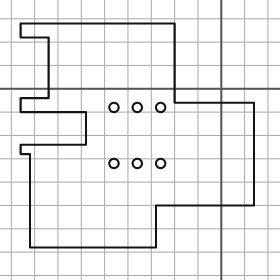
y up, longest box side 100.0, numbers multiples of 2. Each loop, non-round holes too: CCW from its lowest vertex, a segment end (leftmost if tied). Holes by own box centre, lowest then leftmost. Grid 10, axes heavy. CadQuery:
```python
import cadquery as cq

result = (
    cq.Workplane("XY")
    .moveTo(-82.0, -68.0)
    .lineTo(-28.0, -68.0)
    .lineTo(-28.0, -50.0)
    .lineTo(14.0, -50.0)
    .lineTo(14.0, -6.0)
    .lineTo(-20.0, -6.0)
    .lineTo(-20.0, 28.0)
    .lineTo(-86.0, 28.0)
    .lineTo(-86.0, 22.0)
    .lineTo(-74.0, 22.0)
    .lineTo(-74.0, -4.0)
    .lineTo(-86.0, -4.0)
    .lineTo(-86.0, -10.0)
    .lineTo(-58.0, -10.0)
    .lineTo(-58.0, -24.0)
    .lineTo(-86.0, -24.0)
    .lineTo(-86.0, -28.0)
    .lineTo(-82.0, -28.0)
    .close()
    .moveTo(-46.0, -32.0)
    .circle(2.0)
    .moveTo(-36.0, -32.0)
    .circle(2.0)
    .moveTo(-26.0, -32.0)
    .circle(2.0)
    .moveTo(-46.0, -8.0)
    .circle(2.0)
    .moveTo(-36.0, -8.0)
    .circle(2.0)
    .moveTo(-26.0, -8.0)
    .circle(2.0)
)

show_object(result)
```